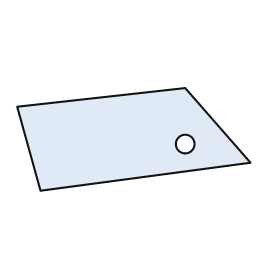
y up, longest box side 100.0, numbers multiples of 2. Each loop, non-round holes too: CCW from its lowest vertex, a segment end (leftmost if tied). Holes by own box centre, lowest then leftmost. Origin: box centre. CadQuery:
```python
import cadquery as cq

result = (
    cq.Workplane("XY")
    .moveTo(-40.0, -22.0)
    .lineTo(50.0, -10.0)
    .lineTo(22.0, 22.0)
    .lineTo(-50.0, 14.0)
    .close()
    .moveTo(22.0, -2.0)
    .circle(4.0)
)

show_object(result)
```